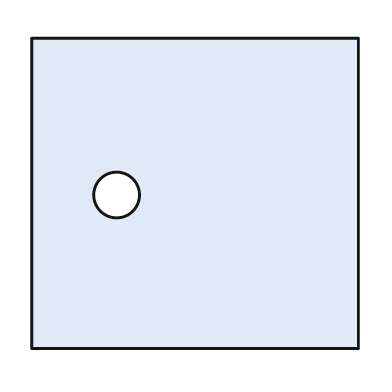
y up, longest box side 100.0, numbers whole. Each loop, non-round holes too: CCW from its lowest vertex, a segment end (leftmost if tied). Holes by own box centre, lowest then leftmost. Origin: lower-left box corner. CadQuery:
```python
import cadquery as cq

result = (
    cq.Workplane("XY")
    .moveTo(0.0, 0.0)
    .lineTo(100.0, 0.0)
    .lineTo(100.0, 95.0)
    .lineTo(0.0, 95.0)
    .close()
    .moveTo(26.0, 47.0)
    .circle(7.0)
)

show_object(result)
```